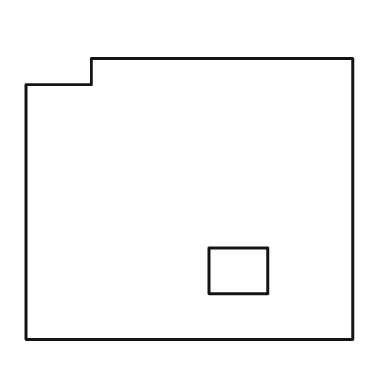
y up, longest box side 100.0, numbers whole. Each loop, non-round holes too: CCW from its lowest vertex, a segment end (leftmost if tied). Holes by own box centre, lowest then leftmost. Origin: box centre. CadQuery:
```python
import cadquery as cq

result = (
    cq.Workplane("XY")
    .moveTo(-50.0, -43.0)
    .lineTo(50.0, -43.0)
    .lineTo(50.0, 43.0)
    .lineTo(-30.0, 43.0)
    .lineTo(-30.0, 35.0)
    .lineTo(-50.0, 35.0)
    .close()
    .moveTo(6.0, -29.0)
    .lineTo(24.0, -29.0)
    .lineTo(24.0, -15.0)
    .lineTo(6.0, -15.0)
    .close()
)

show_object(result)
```